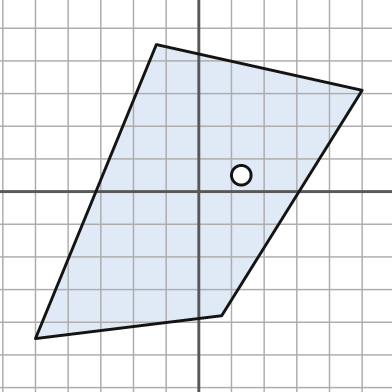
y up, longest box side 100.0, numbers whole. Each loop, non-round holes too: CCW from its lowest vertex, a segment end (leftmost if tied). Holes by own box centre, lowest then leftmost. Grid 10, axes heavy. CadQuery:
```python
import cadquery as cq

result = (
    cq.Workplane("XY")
    .moveTo(-50.0, -45.0)
    .lineTo(7.0, -38.0)
    .lineTo(50.0, 31.0)
    .lineTo(-13.0, 45.0)
    .close()
    .moveTo(13.0, 5.0)
    .circle(3.0)
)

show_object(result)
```